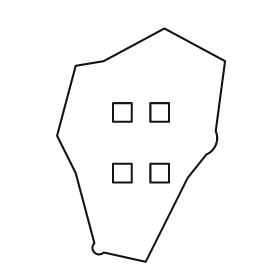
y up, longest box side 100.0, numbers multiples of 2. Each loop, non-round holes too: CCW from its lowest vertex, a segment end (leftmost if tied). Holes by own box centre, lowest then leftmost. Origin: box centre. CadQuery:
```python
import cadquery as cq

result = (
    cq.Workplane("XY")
    .moveTo(2.0, -50.0)
    .lineTo(20.0, -14.0)
    .lineTo(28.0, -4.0)
    .threePointArc((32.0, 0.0), (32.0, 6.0))
    .lineTo(36.0, 36.0)
    .lineTo(10.0, 50.0)
    .lineTo(-16.0, 36.0)
    .lineTo(-28.0, 34.0)
    .lineTo(-36.0, 4.0)
    .lineTo(-28.0, -12.0)
    .lineTo(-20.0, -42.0)
    .threePointArc((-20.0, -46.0), (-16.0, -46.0))
    .close()
    .moveTo(-12.0, -16.0)
    .lineTo(-4.0, -16.0)
    .lineTo(-4.0, -8.0)
    .lineTo(-12.0, -8.0)
    .close()
    .moveTo(4.0, -16.0)
    .lineTo(12.0, -16.0)
    .lineTo(12.0, -8.0)
    .lineTo(4.0, -8.0)
    .close()
    .moveTo(-12.0, 10.0)
    .lineTo(-4.0, 10.0)
    .lineTo(-4.0, 18.0)
    .lineTo(-12.0, 18.0)
    .close()
    .moveTo(4.0, 10.0)
    .lineTo(12.0, 10.0)
    .lineTo(12.0, 18.0)
    .lineTo(4.0, 18.0)
    .close()
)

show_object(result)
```